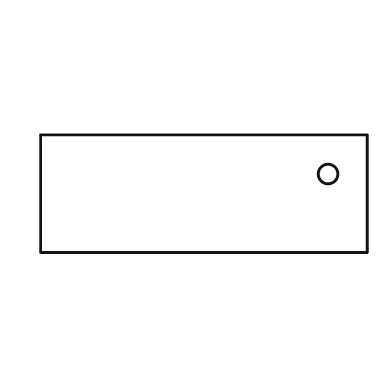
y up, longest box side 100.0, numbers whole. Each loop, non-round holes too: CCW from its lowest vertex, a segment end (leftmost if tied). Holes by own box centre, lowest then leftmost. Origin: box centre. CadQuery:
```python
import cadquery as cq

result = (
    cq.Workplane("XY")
    .moveTo(-50.0, -18.0)
    .lineTo(50.0, -18.0)
    .lineTo(50.0, 18.0)
    .lineTo(-50.0, 18.0)
    .close()
    .moveTo(38.0, 6.0)
    .circle(3.0)
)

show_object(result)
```